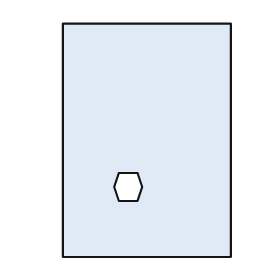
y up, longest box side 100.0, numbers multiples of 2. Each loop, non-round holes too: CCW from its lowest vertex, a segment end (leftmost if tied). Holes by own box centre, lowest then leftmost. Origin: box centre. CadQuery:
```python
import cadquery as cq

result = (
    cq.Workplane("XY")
    .moveTo(-36.0, -50.0)
    .lineTo(36.0, -50.0)
    .lineTo(36.0, 50.0)
    .lineTo(-36.0, 50.0)
    .close()
    .moveTo(-12.0, -26.0)
    .lineTo(-4.0, -26.0)
    .lineTo(-2.0, -20.0)
    .lineTo(-4.0, -14.0)
    .lineTo(-12.0, -14.0)
    .lineTo(-14.0, -20.0)
    .close()
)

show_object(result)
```